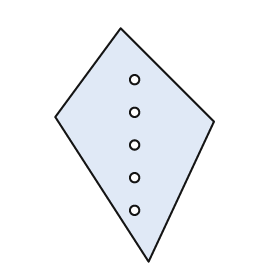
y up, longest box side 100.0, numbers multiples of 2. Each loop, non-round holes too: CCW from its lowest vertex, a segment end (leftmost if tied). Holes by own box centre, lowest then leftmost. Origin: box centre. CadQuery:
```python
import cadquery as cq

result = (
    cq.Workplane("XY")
    .moveTo(6.0, -50.0)
    .lineTo(34.0, 10.0)
    .lineTo(-6.0, 50.0)
    .lineTo(-34.0, 12.0)
    .close()
    .moveTo(0.0, -28.0)
    .circle(2.0)
    .moveTo(0.0, -14.0)
    .circle(2.0)
    .moveTo(0.0, 0.0)
    .circle(2.0)
    .moveTo(0.0, 14.0)
    .circle(2.0)
    .moveTo(0.0, 28.0)
    .circle(2.0)
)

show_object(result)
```